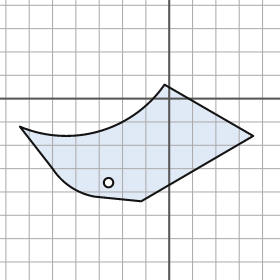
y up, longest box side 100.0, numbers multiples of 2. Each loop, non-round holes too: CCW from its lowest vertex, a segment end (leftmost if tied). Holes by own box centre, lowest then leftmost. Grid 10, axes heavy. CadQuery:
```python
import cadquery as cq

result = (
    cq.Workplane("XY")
    .moveTo(-12.0, -44.0)
    .lineTo(36.0, -16.0)
    .lineTo(-2.0, 6.0)
    .threePointArc((-30.0, -14.0), (-64.0, -12.0))
    .lineTo(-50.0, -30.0)
    .threePointArc((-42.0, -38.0), (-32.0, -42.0))
    .close()
    .moveTo(-26.0, -36.0)
    .circle(2.0)
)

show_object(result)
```